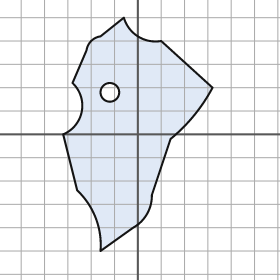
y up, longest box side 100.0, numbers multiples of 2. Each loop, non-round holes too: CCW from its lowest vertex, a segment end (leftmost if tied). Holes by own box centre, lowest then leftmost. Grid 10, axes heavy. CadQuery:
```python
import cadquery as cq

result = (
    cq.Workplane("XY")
    .moveTo(-16.0, -50.0)
    .lineTo(-2.0, -40.0)
    .threePointArc((4.0, -34.0), (6.0, -26.0))
    .lineTo(14.0, -2.0)
    .threePointArc((24.0, 8.0), (32.0, 20.0))
    .lineTo(10.0, 40.0)
    .threePointArc((0.0, 42.0), (-6.0, 50.0))
    .lineTo(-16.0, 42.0)
    .threePointArc((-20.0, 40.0), (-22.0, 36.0))
    .lineTo(-28.0, 22.0)
    .threePointArc((-24.0, 10.0), (-32.0, 0.0))
    .lineTo(-26.0, -24.0)
    .threePointArc((-18.0, -36.0), (-16.0, -50.0))
    .close()
    .moveTo(-12.0, 18.0)
    .circle(4.0)
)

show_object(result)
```